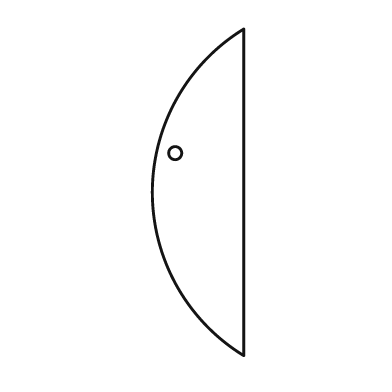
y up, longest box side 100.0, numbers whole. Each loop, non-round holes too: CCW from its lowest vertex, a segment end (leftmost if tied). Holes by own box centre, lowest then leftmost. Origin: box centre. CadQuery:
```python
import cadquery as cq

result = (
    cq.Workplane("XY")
    .moveTo(14.0, -50.0)
    .lineTo(14.0, 50.0)
    .threePointArc((-14.0, 0.0), (14.0, -50.0))
    .close()
    .moveTo(-7.0, 12.0)
    .circle(2.0)
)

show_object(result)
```